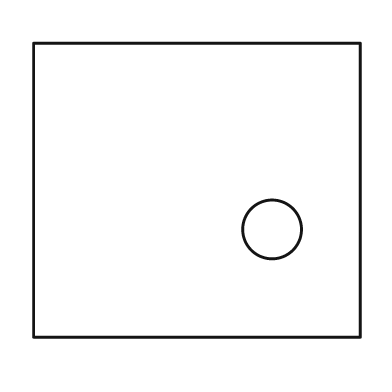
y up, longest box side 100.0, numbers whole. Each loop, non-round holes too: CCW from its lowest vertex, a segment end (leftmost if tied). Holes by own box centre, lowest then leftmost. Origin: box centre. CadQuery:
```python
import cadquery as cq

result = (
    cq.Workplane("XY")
    .moveTo(-50.0, -45.0)
    .lineTo(50.0, -45.0)
    .lineTo(50.0, 45.0)
    .lineTo(-50.0, 45.0)
    .close()
    .moveTo(23.0, -12.0)
    .circle(9.0)
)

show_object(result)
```